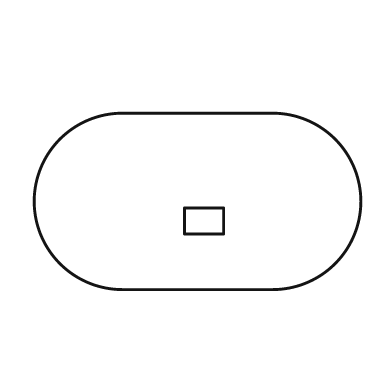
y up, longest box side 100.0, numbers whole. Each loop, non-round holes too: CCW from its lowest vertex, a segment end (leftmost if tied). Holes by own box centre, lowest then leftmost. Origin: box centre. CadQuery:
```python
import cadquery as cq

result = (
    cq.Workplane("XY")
    .moveTo(-23.0, -27.0)
    .lineTo(23.0, -27.0)
    .threePointArc((50.0, 0.0), (23.0, 27.0))
    .lineTo(-23.0, 27.0)
    .threePointArc((-50.0, 0.0), (-23.0, -27.0))
    .close()
    .moveTo(-4.0, -10.0)
    .lineTo(8.0, -10.0)
    .lineTo(8.0, -2.0)
    .lineTo(-4.0, -2.0)
    .close()
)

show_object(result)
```